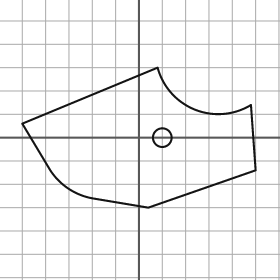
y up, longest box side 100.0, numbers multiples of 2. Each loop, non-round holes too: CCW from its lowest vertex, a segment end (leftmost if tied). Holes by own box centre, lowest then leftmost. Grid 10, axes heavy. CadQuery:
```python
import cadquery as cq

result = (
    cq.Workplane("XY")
    .moveTo(4.0, -30.0)
    .lineTo(50.0, -14.0)
    .lineTo(48.0, 14.0)
    .threePointArc((24.0, 12.0), (8.0, 30.0))
    .lineTo(-50.0, 6.0)
    .lineTo(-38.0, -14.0)
    .threePointArc((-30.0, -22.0), (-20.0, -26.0))
    .close()
    .moveTo(10.0, 0.0)
    .circle(4.0)
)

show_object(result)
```